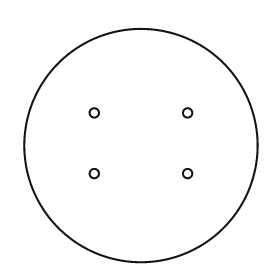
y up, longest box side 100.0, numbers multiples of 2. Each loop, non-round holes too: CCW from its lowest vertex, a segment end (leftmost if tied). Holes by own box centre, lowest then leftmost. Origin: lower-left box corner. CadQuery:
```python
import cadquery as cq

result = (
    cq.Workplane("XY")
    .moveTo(50.0, 50.0)
    .circle(50.0)
    .moveTo(30.0, 38.0)
    .circle(2.0)
    .moveTo(70.0, 38.0)
    .circle(2.0)
    .moveTo(30.0, 64.0)
    .circle(2.0)
    .moveTo(70.0, 64.0)
    .circle(2.0)
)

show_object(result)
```